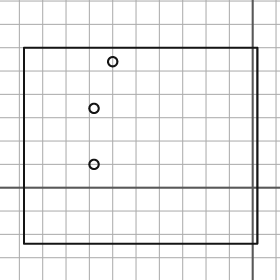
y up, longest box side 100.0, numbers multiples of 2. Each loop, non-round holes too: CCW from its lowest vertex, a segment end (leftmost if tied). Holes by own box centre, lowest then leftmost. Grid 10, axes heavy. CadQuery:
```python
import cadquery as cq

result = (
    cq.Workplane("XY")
    .moveTo(-98.0, -24.0)
    .lineTo(2.0, -24.0)
    .lineTo(2.0, 60.0)
    .lineTo(-98.0, 60.0)
    .close()
    .moveTo(-68.0, 10.0)
    .circle(2.0)
    .moveTo(-68.0, 34.0)
    .circle(2.0)
    .moveTo(-60.0, 54.0)
    .circle(2.0)
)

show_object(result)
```